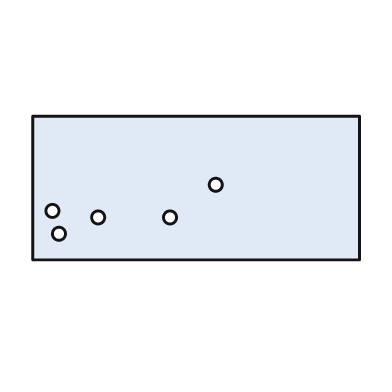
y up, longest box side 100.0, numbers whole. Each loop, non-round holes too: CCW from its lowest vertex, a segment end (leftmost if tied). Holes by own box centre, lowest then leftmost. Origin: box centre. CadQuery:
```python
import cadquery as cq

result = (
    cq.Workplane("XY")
    .moveTo(-50.0, -22.0)
    .lineTo(50.0, -22.0)
    .lineTo(50.0, 22.0)
    .lineTo(-50.0, 22.0)
    .close()
    .moveTo(-42.0, -14.0)
    .circle(2.0)
    .moveTo(-30.0, -9.0)
    .circle(2.0)
    .moveTo(-8.0, -9.0)
    .circle(2.0)
    .moveTo(-44.0, -7.0)
    .circle(2.0)
    .moveTo(6.0, 1.0)
    .circle(2.0)
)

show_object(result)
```